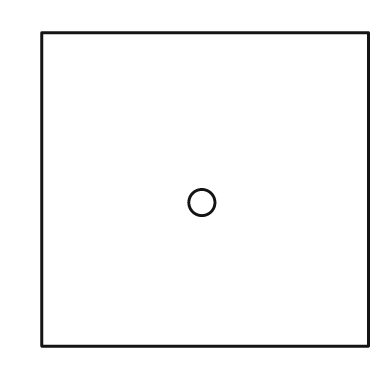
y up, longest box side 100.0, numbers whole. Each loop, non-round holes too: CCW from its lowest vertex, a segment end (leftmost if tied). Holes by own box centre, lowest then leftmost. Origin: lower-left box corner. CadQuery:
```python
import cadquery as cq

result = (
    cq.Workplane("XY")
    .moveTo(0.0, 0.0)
    .lineTo(100.0, 0.0)
    .lineTo(100.0, 96.0)
    .lineTo(0.0, 96.0)
    .close()
    .moveTo(49.0, 44.0)
    .circle(4.0)
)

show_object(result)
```